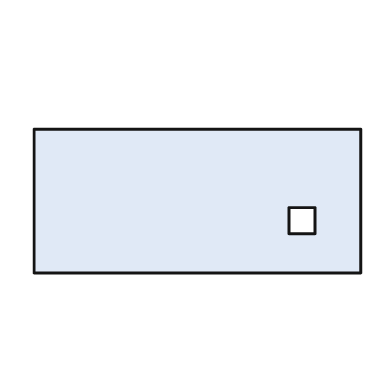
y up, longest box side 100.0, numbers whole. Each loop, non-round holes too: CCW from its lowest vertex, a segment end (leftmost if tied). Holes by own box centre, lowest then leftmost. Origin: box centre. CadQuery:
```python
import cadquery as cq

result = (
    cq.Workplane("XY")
    .moveTo(-50.0, -22.0)
    .lineTo(50.0, -22.0)
    .lineTo(50.0, 22.0)
    .lineTo(-50.0, 22.0)
    .close()
    .moveTo(28.0, -10.0)
    .lineTo(36.0, -10.0)
    .lineTo(36.0, -2.0)
    .lineTo(28.0, -2.0)
    .close()
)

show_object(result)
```